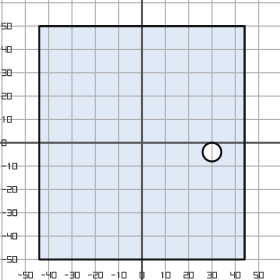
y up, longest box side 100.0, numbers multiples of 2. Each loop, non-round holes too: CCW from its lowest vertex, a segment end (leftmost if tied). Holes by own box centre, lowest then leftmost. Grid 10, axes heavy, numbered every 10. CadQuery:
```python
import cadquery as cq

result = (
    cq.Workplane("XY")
    .moveTo(-44.0, -50.0)
    .lineTo(44.0, -50.0)
    .lineTo(44.0, 50.0)
    .lineTo(-44.0, 50.0)
    .close()
    .moveTo(30.0, -4.0)
    .circle(4.0)
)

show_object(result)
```